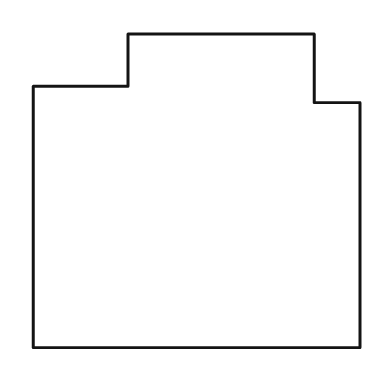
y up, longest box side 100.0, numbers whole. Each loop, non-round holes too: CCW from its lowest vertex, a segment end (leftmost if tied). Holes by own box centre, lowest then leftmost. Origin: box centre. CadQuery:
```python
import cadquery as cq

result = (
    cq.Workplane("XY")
    .moveTo(-50.0, -48.0)
    .lineTo(50.0, -48.0)
    .lineTo(50.0, 27.0)
    .lineTo(36.0, 27.0)
    .lineTo(36.0, 48.0)
    .lineTo(-21.0, 48.0)
    .lineTo(-21.0, 32.0)
    .lineTo(-50.0, 32.0)
    .close()
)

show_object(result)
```